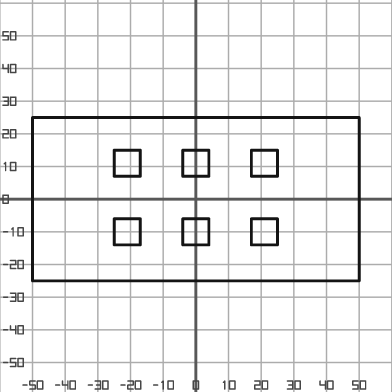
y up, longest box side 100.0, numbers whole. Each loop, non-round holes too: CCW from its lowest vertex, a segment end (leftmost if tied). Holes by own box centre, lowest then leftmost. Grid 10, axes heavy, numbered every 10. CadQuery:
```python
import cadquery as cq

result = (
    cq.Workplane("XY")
    .moveTo(-50.0, -25.0)
    .lineTo(50.0, -25.0)
    .lineTo(50.0, 25.0)
    .lineTo(-50.0, 25.0)
    .close()
    .moveTo(-25.0, -14.0)
    .lineTo(-17.0, -14.0)
    .lineTo(-17.0, -6.0)
    .lineTo(-25.0, -6.0)
    .close()
    .moveTo(-4.0, -14.0)
    .lineTo(4.0, -14.0)
    .lineTo(4.0, -6.0)
    .lineTo(-4.0, -6.0)
    .close()
    .moveTo(17.0, -14.0)
    .lineTo(25.0, -14.0)
    .lineTo(25.0, -6.0)
    .lineTo(17.0, -6.0)
    .close()
    .moveTo(-25.0, 7.0)
    .lineTo(-17.0, 7.0)
    .lineTo(-17.0, 15.0)
    .lineTo(-25.0, 15.0)
    .close()
    .moveTo(-4.0, 7.0)
    .lineTo(4.0, 7.0)
    .lineTo(4.0, 15.0)
    .lineTo(-4.0, 15.0)
    .close()
    .moveTo(17.0, 7.0)
    .lineTo(25.0, 7.0)
    .lineTo(25.0, 15.0)
    .lineTo(17.0, 15.0)
    .close()
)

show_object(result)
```